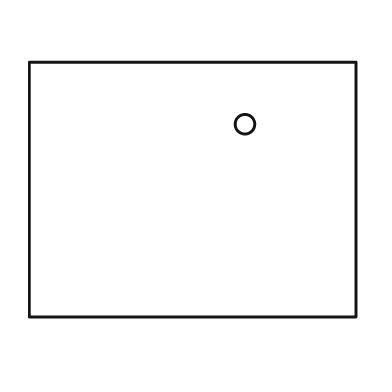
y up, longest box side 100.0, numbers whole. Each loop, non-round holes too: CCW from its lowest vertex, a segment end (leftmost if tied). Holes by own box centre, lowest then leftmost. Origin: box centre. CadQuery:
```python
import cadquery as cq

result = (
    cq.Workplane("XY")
    .moveTo(-50.0, -39.0)
    .lineTo(50.0, -39.0)
    .lineTo(50.0, 39.0)
    .lineTo(-50.0, 39.0)
    .close()
    .moveTo(16.0, 20.0)
    .circle(3.0)
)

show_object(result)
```